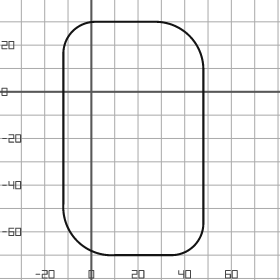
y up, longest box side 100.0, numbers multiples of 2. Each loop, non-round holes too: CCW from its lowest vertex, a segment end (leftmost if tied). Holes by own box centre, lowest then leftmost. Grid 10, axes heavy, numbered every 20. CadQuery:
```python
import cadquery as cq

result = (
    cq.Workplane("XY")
    .moveTo(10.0, -70.0)
    .lineTo(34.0, -70.0)
    .threePointArc((44.0, -66.0), (48.0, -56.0))
    .lineTo(48.0, 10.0)
    .threePointArc((42.0, 24.0), (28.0, 30.0))
    .lineTo(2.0, 30.0)
    .threePointArc((-8.0, 26.0), (-12.0, 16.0))
    .lineTo(-12.0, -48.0)
    .threePointArc((-6.0, -64.0), (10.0, -70.0))
    .close()
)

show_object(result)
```